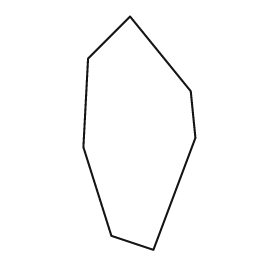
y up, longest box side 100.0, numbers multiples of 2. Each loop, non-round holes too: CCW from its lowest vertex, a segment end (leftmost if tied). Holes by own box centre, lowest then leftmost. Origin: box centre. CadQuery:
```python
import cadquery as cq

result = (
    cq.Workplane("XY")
    .moveTo(6.0, -50.0)
    .lineTo(24.0, -2.0)
    .lineTo(22.0, 18.0)
    .lineTo(-4.0, 50.0)
    .lineTo(-22.0, 32.0)
    .lineTo(-24.0, -6.0)
    .lineTo(-12.0, -44.0)
    .close()
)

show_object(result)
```